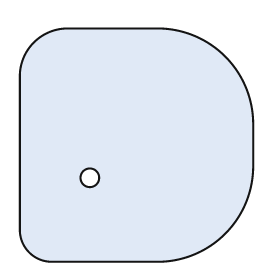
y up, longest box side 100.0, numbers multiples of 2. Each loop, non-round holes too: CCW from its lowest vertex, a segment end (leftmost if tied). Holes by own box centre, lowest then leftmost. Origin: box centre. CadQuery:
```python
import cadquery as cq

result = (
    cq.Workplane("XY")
    .moveTo(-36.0, -50.0)
    .lineTo(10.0, -50.0)
    .threePointArc((38.0, -38.0), (50.0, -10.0))
    .lineTo(50.0, 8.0)
    .threePointArc((38.0, 38.0), (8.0, 50.0))
    .lineTo(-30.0, 50.0)
    .threePointArc((-44.0, 44.0), (-50.0, 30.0))
    .lineTo(-50.0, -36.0)
    .threePointArc((-46.0, -46.0), (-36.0, -50.0))
    .close()
    .moveTo(-20.0, -14.0)
    .circle(4.0)
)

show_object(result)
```